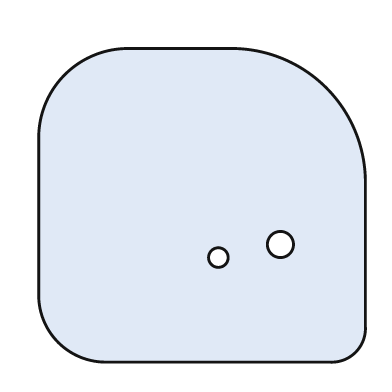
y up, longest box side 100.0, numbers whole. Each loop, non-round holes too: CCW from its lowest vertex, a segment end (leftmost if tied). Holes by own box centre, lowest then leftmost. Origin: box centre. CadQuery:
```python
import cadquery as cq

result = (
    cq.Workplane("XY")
    .moveTo(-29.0, -48.0)
    .lineTo(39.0, -48.0)
    .threePointArc((47.0, -45.0), (50.0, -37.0))
    .lineTo(50.0, 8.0)
    .threePointArc((38.0, 36.0), (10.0, 48.0))
    .lineTo(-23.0, 48.0)
    .threePointArc((-42.0, 40.0), (-50.0, 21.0))
    .lineTo(-50.0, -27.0)
    .threePointArc((-44.0, -42.0), (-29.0, -48.0))
    .close()
    .moveTo(5.0, -16.0)
    .circle(3.0)
    .moveTo(24.0, -12.0)
    .circle(4.0)
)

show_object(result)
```